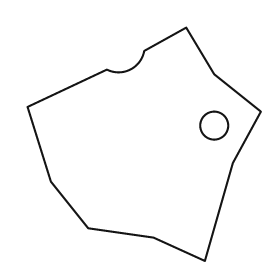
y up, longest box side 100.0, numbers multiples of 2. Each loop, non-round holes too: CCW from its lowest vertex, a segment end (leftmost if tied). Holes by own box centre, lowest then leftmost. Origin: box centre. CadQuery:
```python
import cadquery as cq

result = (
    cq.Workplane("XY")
    .moveTo(26.0, -50.0)
    .lineTo(38.0, -8.0)
    .lineTo(50.0, 14.0)
    .lineTo(30.0, 30.0)
    .lineTo(18.0, 50.0)
    .lineTo(0.0, 40.0)
    .threePointArc((-6.0, 32.0), (-16.0, 32.0))
    .lineTo(-50.0, 16.0)
    .lineTo(-40.0, -16.0)
    .lineTo(-24.0, -36.0)
    .lineTo(4.0, -40.0)
    .close()
    .moveTo(30.0, 8.0)
    .circle(6.0)
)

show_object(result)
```